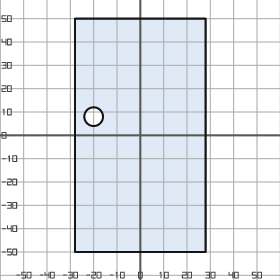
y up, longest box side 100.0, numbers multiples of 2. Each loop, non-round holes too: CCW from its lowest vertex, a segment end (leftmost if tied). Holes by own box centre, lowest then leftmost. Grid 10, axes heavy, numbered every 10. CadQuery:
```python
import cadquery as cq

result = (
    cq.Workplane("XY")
    .moveTo(-28.0, -50.0)
    .lineTo(28.0, -50.0)
    .lineTo(28.0, 50.0)
    .lineTo(-28.0, 50.0)
    .close()
    .moveTo(-20.0, 8.0)
    .circle(4.0)
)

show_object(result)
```